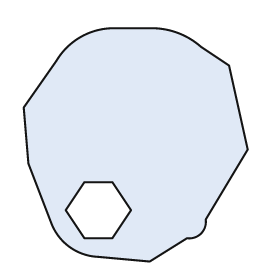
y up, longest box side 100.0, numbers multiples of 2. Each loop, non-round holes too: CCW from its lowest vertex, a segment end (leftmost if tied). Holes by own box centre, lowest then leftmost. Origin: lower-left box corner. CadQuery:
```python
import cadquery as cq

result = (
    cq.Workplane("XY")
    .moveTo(54.0, 0.0)
    .lineTo(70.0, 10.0)
    .threePointArc((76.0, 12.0), (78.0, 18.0))
    .lineTo(96.0, 48.0)
    .lineTo(88.0, 84.0)
    .lineTo(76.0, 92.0)
    .threePointArc((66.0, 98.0), (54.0, 100.0))
    .lineTo(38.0, 100.0)
    .threePointArc((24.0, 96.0), (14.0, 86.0))
    .lineTo(0.0, 66.0)
    .lineTo(2.0, 42.0)
    .lineTo(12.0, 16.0)
    .threePointArc((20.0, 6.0), (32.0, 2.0))
    .close()
    .moveTo(26.0, 10.0)
    .lineTo(38.0, 10.0)
    .lineTo(46.0, 22.0)
    .lineTo(38.0, 34.0)
    .lineTo(26.0, 34.0)
    .lineTo(18.0, 22.0)
    .close()
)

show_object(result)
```